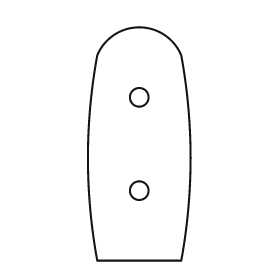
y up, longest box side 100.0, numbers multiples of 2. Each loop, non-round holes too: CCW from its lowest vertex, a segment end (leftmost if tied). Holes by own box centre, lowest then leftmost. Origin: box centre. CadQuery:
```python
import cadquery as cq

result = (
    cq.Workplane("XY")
    .moveTo(-18.0, -50.0)
    .lineTo(18.0, -50.0)
    .threePointArc((22.0, -6.0), (18.0, 38.0))
    .threePointArc((0.0, 50.0), (-18.0, 38.0))
    .threePointArc((-22.0, -6.0), (-18.0, -50.0))
    .close()
    .moveTo(0.0, -20.0)
    .circle(4.0)
    .moveTo(0.0, 20.0)
    .circle(4.0)
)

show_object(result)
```